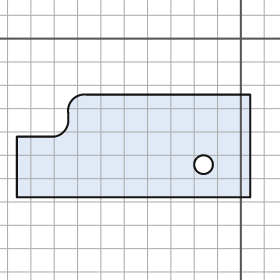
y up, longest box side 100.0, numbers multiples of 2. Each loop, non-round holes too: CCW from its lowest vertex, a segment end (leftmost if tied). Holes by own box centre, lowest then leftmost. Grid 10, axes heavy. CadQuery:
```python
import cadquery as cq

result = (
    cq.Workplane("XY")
    .moveTo(-96.0, -68.0)
    .lineTo(4.0, -68.0)
    .lineTo(4.0, -24.0)
    .lineTo(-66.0, -24.0)
    .threePointArc((-72.0, -26.0), (-74.0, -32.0))
    .lineTo(-74.0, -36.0)
    .threePointArc((-76.0, -40.0), (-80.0, -42.0))
    .lineTo(-96.0, -42.0)
    .close()
    .moveTo(-16.0, -54.0)
    .circle(4.0)
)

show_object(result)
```